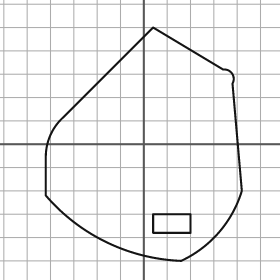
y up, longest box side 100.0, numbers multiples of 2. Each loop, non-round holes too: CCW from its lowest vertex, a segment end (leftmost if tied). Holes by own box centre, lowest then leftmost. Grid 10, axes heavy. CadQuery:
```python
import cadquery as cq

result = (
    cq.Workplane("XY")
    .moveTo(16.0, -50.0)
    .threePointArc((32.0, -38.0), (42.0, -20.0))
    .lineTo(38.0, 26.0)
    .threePointArc((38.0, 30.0), (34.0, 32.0))
    .lineTo(4.0, 50.0)
    .lineTo(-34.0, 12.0)
    .threePointArc((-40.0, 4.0), (-42.0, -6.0))
    .lineTo(-42.0, -22.0)
    .threePointArc((-16.0, -42.0), (16.0, -50.0))
    .close()
    .moveTo(4.0, -38.0)
    .lineTo(20.0, -38.0)
    .lineTo(20.0, -30.0)
    .lineTo(4.0, -30.0)
    .close()
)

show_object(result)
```